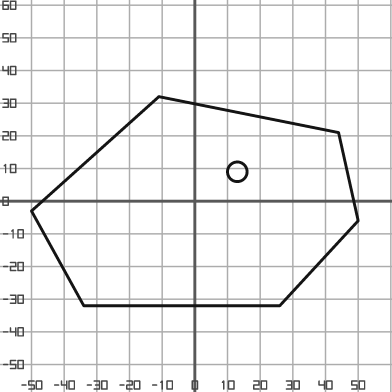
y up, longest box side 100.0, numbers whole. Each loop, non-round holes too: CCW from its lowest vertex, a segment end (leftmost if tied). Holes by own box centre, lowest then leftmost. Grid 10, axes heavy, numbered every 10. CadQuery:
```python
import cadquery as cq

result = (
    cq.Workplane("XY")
    .moveTo(-34.0, -32.0)
    .lineTo(26.0, -32.0)
    .lineTo(50.0, -6.0)
    .lineTo(44.0, 21.0)
    .lineTo(-11.0, 32.0)
    .lineTo(-50.0, -3.0)
    .close()
    .moveTo(13.0, 9.0)
    .circle(3.0)
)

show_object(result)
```